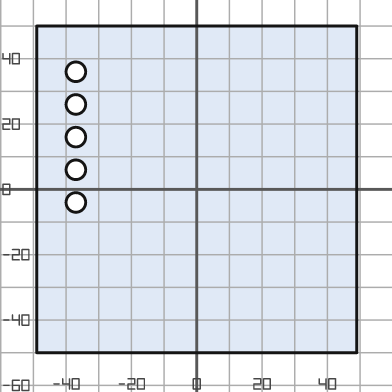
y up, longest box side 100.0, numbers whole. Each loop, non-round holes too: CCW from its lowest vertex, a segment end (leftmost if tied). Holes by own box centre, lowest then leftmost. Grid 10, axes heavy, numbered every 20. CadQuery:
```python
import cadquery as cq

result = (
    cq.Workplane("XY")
    .moveTo(-49.0, -50.0)
    .lineTo(49.0, -50.0)
    .lineTo(49.0, 50.0)
    .lineTo(-49.0, 50.0)
    .close()
    .moveTo(-37.0, -4.0)
    .circle(3.0)
    .moveTo(-37.0, 6.0)
    .circle(3.0)
    .moveTo(-37.0, 16.0)
    .circle(3.0)
    .moveTo(-37.0, 26.0)
    .circle(3.0)
    .moveTo(-37.0, 36.0)
    .circle(3.0)
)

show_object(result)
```